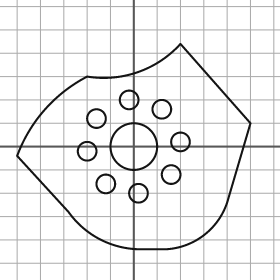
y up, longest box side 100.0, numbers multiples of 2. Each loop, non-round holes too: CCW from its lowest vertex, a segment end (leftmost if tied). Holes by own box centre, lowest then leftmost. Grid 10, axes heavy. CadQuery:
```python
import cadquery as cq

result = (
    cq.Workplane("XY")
    .moveTo(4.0, -44.0)
    .lineTo(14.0, -44.0)
    .threePointArc((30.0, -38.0), (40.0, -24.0))
    .lineTo(50.0, 10.0)
    .lineTo(20.0, 44.0)
    .threePointArc((2.0, 32.0), (-20.0, 30.0))
    .threePointArc((-38.0, 16.0), (-50.0, -4.0))
    .lineTo(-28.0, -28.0)
    .threePointArc((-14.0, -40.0), (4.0, -44.0))
    .close()
    .moveTo(2.0, -20.0)
    .circle(4.0)
    .moveTo(-12.0, -16.0)
    .circle(4.0)
    .moveTo(16.0, -12.0)
    .circle(4.0)
    .moveTo(-20.0, -2.0)
    .circle(4.0)
    .moveTo(0.0, 0.0)
    .circle(10.0)
    .moveTo(20.0, 2.0)
    .circle(4.0)
    .moveTo(-16.0, 12.0)
    .circle(4.0)
    .moveTo(12.0, 16.0)
    .circle(4.0)
    .moveTo(-2.0, 20.0)
    .circle(4.0)
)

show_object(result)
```